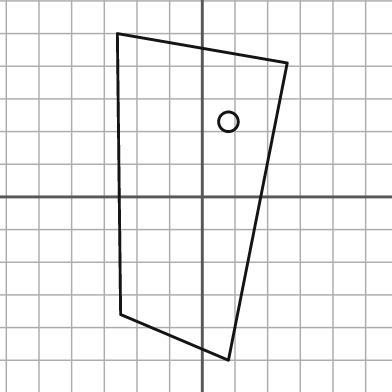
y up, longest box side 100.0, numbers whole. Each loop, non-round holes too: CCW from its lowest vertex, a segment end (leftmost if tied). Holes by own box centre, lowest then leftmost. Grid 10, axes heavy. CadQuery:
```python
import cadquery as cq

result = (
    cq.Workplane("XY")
    .moveTo(8.0, -50.0)
    .lineTo(26.0, 41.0)
    .lineTo(-26.0, 50.0)
    .lineTo(-25.0, -36.0)
    .close()
    .moveTo(8.0, 23.0)
    .circle(3.0)
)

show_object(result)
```